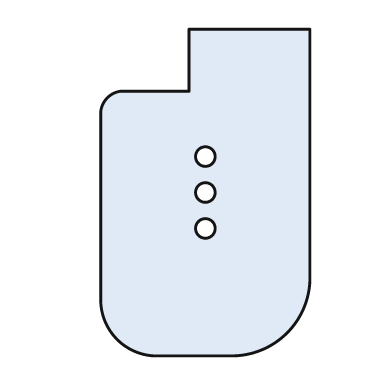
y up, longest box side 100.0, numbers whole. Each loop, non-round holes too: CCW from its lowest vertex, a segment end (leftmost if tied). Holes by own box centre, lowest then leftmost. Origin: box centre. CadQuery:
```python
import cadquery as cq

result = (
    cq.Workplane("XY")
    .moveTo(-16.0, -50.0)
    .lineTo(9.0, -50.0)
    .threePointArc((25.0, -43.0), (32.0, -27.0))
    .lineTo(32.0, 50.0)
    .lineTo(-5.0, 50.0)
    .lineTo(-5.0, 31.0)
    .lineTo(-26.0, 31.0)
    .threePointArc((-30.0, 29.0), (-32.0, 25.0))
    .lineTo(-32.0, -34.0)
    .threePointArc((-27.0, -45.0), (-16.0, -50.0))
    .close()
    .moveTo(0.0, -11.0)
    .circle(3.0)
    .moveTo(0.0, 0.0)
    .circle(3.0)
    .moveTo(0.0, 11.0)
    .circle(3.0)
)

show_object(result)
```